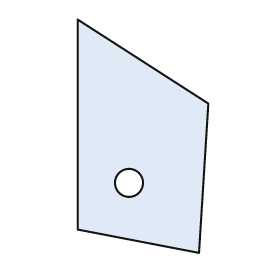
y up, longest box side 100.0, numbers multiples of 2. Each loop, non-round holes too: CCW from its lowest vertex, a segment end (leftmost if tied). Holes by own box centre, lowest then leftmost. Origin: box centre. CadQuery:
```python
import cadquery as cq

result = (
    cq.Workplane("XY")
    .moveTo(24.0, -50.0)
    .lineTo(28.0, 14.0)
    .lineTo(-28.0, 50.0)
    .lineTo(-28.0, -40.0)
    .close()
    .moveTo(-6.0, -20.0)
    .circle(6.0)
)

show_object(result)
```